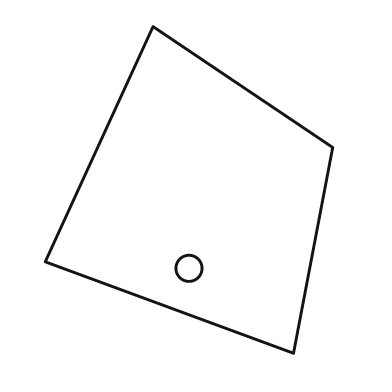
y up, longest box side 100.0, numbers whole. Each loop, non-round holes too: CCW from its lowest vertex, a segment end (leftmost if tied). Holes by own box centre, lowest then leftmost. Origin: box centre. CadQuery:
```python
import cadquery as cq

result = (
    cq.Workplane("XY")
    .moveTo(32.0, -50.0)
    .lineTo(44.0, 13.0)
    .lineTo(-11.0, 50.0)
    .lineTo(-44.0, -22.0)
    .close()
    .moveTo(0.0, -24.0)
    .circle(4.0)
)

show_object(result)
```